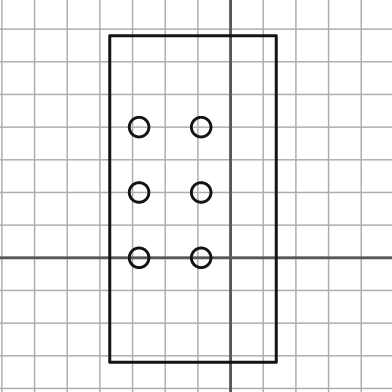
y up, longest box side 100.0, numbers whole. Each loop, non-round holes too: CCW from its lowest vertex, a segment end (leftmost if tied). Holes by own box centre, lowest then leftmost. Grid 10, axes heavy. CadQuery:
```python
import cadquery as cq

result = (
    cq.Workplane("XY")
    .moveTo(-37.0, -32.0)
    .lineTo(14.0, -32.0)
    .lineTo(14.0, 68.0)
    .lineTo(-37.0, 68.0)
    .close()
    .moveTo(-28.0, 0.0)
    .circle(3.0)
    .moveTo(-9.0, 0.0)
    .circle(3.0)
    .moveTo(-28.0, 20.0)
    .circle(3.0)
    .moveTo(-9.0, 20.0)
    .circle(3.0)
    .moveTo(-28.0, 40.0)
    .circle(3.0)
    .moveTo(-9.0, 40.0)
    .circle(3.0)
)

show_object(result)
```